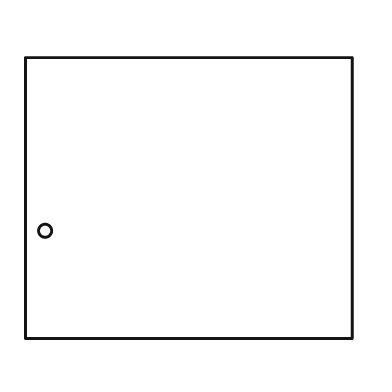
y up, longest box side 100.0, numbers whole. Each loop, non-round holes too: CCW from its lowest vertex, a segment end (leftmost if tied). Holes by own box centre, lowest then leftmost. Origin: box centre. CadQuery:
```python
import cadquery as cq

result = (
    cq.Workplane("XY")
    .moveTo(-50.0, -43.0)
    .lineTo(50.0, -43.0)
    .lineTo(50.0, 43.0)
    .lineTo(-50.0, 43.0)
    .close()
    .moveTo(-44.0, -10.0)
    .circle(2.0)
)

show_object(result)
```